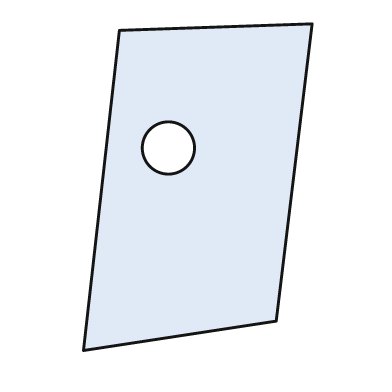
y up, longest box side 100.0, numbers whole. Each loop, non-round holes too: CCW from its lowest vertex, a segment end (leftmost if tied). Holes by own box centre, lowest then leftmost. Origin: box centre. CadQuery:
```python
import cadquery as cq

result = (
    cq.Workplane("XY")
    .moveTo(-35.0, -50.0)
    .lineTo(24.0, -41.0)
    .lineTo(35.0, 50.0)
    .lineTo(-24.0, 48.0)
    .close()
    .moveTo(-9.0, 12.0)
    .circle(8.0)
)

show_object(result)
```